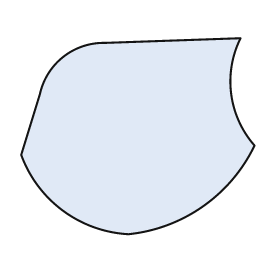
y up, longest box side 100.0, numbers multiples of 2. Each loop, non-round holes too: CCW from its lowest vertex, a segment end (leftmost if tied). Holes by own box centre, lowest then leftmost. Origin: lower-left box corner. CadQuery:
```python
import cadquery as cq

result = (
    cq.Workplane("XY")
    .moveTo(46.0, 0.0)
    .threePointArc((78.0, 12.0), (100.0, 38.0))
    .threePointArc((90.0, 60.0), (94.0, 84.0))
    .lineTo(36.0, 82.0)
    .threePointArc((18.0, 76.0), (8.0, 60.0))
    .lineTo(0.0, 34.0)
    .threePointArc((18.0, 10.0), (46.0, 0.0))
    .close()
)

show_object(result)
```